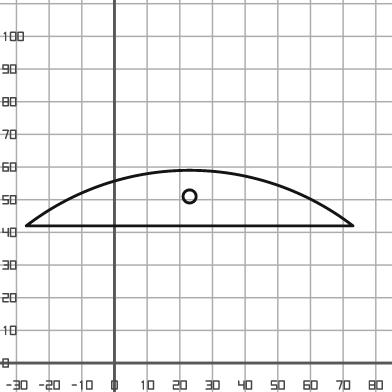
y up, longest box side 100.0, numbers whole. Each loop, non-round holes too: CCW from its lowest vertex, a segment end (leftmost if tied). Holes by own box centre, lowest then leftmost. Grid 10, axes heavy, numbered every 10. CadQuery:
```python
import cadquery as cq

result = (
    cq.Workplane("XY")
    .moveTo(-27.0, 42.0)
    .lineTo(73.0, 42.0)
    .threePointArc((23.0, 59.0), (-27.0, 42.0))
    .close()
    .moveTo(23.0, 51.0)
    .circle(2.0)
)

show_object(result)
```